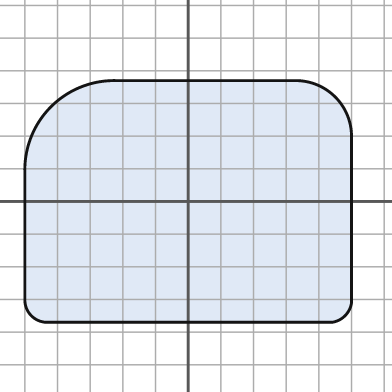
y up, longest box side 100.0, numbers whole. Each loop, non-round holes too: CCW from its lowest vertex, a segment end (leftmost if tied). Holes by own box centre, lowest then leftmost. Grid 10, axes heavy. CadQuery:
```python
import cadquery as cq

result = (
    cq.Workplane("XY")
    .moveTo(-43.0, -37.0)
    .lineTo(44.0, -37.0)
    .threePointArc((48.0, -35.0), (50.0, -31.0))
    .lineTo(50.0, 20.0)
    .threePointArc((45.0, 32.0), (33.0, 37.0))
    .lineTo(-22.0, 37.0)
    .threePointArc((-42.0, 29.0), (-50.0, 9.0))
    .lineTo(-50.0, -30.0)
    .threePointArc((-48.0, -35.0), (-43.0, -37.0))
    .close()
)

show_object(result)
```